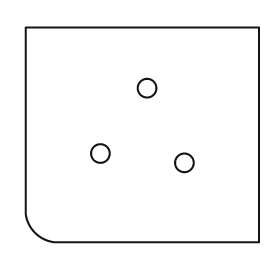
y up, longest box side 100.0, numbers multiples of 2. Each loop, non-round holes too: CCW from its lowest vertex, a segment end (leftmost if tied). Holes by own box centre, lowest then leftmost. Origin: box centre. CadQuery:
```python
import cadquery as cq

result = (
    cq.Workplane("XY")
    .moveTo(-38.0, -46.0)
    .lineTo(50.0, -46.0)
    .lineTo(50.0, 46.0)
    .lineTo(-50.0, 46.0)
    .lineTo(-50.0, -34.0)
    .threePointArc((-46.0, -42.0), (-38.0, -46.0))
    .close()
    .moveTo(18.0, -12.0)
    .circle(4.0)
    .moveTo(-18.0, -8.0)
    .circle(4.0)
    .moveTo(2.0, 20.0)
    .circle(4.0)
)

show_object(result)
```